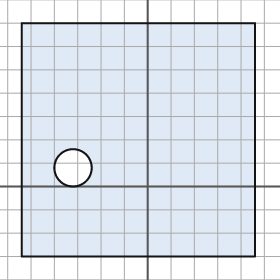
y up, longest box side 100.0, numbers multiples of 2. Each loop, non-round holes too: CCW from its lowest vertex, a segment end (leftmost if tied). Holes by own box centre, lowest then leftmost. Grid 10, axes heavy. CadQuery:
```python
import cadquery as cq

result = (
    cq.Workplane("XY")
    .moveTo(-54.0, -30.0)
    .lineTo(46.0, -30.0)
    .lineTo(46.0, 70.0)
    .lineTo(-54.0, 70.0)
    .close()
    .moveTo(-32.0, 8.0)
    .circle(8.0)
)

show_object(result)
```